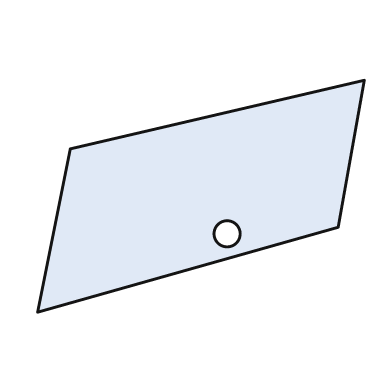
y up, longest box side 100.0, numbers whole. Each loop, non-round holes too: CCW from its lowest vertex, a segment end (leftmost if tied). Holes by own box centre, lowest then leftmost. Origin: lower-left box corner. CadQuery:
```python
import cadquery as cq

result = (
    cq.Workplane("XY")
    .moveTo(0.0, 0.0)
    .lineTo(92.0, 26.0)
    .lineTo(100.0, 71.0)
    .lineTo(10.0, 50.0)
    .close()
    .moveTo(58.0, 24.0)
    .circle(4.0)
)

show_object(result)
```